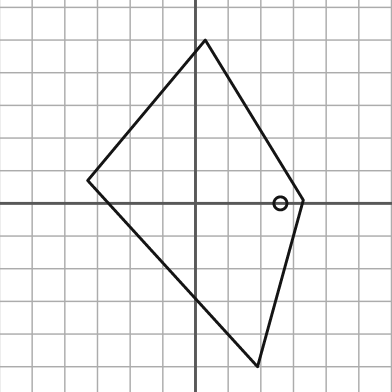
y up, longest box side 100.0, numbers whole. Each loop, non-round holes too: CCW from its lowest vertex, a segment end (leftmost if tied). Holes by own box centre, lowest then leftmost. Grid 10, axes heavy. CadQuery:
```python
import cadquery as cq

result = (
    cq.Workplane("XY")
    .moveTo(19.0, -50.0)
    .lineTo(33.0, 1.0)
    .lineTo(3.0, 50.0)
    .lineTo(-33.0, 7.0)
    .close()
    .moveTo(26.0, 0.0)
    .circle(2.0)
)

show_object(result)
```